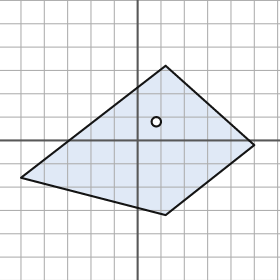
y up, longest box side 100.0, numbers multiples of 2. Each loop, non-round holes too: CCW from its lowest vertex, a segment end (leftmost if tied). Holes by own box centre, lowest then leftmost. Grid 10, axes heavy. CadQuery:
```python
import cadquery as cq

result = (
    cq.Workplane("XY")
    .moveTo(12.0, -32.0)
    .lineTo(50.0, -2.0)
    .lineTo(12.0, 32.0)
    .lineTo(-50.0, -16.0)
    .close()
    .moveTo(8.0, 8.0)
    .circle(2.0)
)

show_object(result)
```